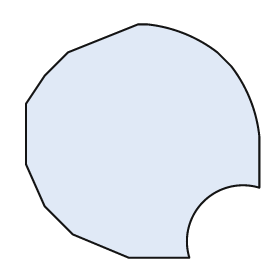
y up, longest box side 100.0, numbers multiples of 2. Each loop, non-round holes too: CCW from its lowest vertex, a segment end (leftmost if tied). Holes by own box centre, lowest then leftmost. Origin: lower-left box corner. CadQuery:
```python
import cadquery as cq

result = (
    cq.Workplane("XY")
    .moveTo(44.0, 0.0)
    .lineTo(70.0, 0.0)
    .threePointArc((76.0, 24.0), (100.0, 30.0))
    .lineTo(100.0, 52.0)
    .threePointArc((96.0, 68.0), (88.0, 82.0))
    .lineTo(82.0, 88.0)
    .threePointArc((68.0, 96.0), (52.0, 100.0))
    .lineTo(48.0, 100.0)
    .lineTo(18.0, 88.0)
    .lineTo(8.0, 78.0)
    .lineTo(0.0, 66.0)
    .lineTo(0.0, 40.0)
    .lineTo(8.0, 22.0)
    .lineTo(20.0, 10.0)
    .close()
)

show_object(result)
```